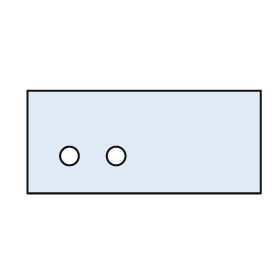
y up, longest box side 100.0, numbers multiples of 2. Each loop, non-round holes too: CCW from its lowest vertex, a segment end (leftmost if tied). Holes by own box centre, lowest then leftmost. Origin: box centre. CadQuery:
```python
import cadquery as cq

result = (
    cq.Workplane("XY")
    .moveTo(-50.0, -22.0)
    .lineTo(50.0, -22.0)
    .lineTo(50.0, 22.0)
    .lineTo(-50.0, 22.0)
    .close()
    .moveTo(-32.0, -6.0)
    .circle(4.0)
    .moveTo(-12.0, -6.0)
    .circle(4.0)
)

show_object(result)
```